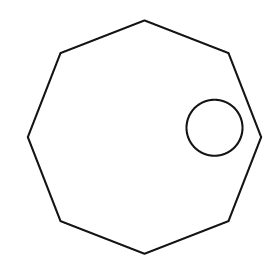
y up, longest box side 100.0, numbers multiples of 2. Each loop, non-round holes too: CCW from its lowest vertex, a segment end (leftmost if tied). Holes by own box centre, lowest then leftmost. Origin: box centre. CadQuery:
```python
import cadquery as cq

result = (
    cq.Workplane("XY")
    .moveTo(0.0, -50.0)
    .lineTo(36.0, -36.0)
    .lineTo(50.0, 0.0)
    .lineTo(36.0, 36.0)
    .lineTo(0.0, 50.0)
    .lineTo(-36.0, 36.0)
    .lineTo(-50.0, 0.0)
    .lineTo(-36.0, -36.0)
    .close()
    .moveTo(30.0, 4.0)
    .circle(12.0)
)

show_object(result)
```